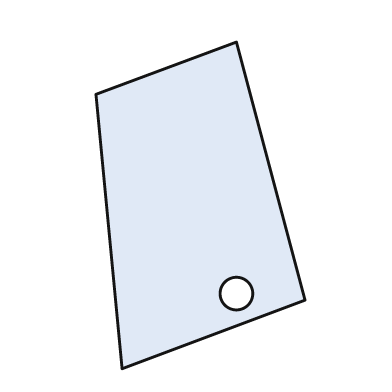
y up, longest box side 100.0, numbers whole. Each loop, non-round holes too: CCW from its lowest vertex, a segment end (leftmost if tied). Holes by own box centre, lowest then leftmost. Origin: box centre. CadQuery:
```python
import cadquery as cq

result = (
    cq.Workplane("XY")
    .moveTo(-24.0, -50.0)
    .lineTo(32.0, -29.0)
    .lineTo(11.0, 50.0)
    .lineTo(-32.0, 34.0)
    .close()
    .moveTo(11.0, -27.0)
    .circle(5.0)
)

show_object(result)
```